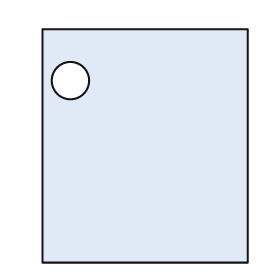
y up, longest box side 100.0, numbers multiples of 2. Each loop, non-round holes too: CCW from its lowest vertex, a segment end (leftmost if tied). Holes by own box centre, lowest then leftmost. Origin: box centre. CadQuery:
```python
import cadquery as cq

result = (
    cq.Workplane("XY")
    .moveTo(-44.0, -50.0)
    .lineTo(44.0, -50.0)
    .lineTo(44.0, 50.0)
    .lineTo(-44.0, 50.0)
    .close()
    .moveTo(-32.0, 28.0)
    .circle(8.0)
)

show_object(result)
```